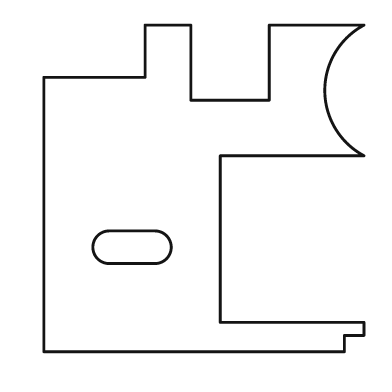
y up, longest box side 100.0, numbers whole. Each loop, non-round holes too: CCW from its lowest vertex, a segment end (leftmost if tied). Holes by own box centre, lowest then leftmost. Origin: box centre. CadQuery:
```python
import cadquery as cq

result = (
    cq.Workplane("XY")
    .moveTo(-49.0, -50.0)
    .lineTo(43.0, -50.0)
    .lineTo(43.0, -45.0)
    .lineTo(49.0, -45.0)
    .lineTo(49.0, -41.0)
    .lineTo(5.0, -41.0)
    .lineTo(5.0, 10.0)
    .lineTo(49.0, 10.0)
    .threePointArc((37.0, 30.0), (49.0, 50.0))
    .lineTo(20.0, 50.0)
    .lineTo(20.0, 27.0)
    .lineTo(-4.0, 27.0)
    .lineTo(-4.0, 50.0)
    .lineTo(-18.0, 50.0)
    .lineTo(-18.0, 34.0)
    .lineTo(-49.0, 34.0)
    .close()
    .moveTo(-29.0, -23.0)
    .lineTo(-15.0, -23.0)
    .threePointArc((-10.0, -18.0), (-15.0, -13.0))
    .lineTo(-29.0, -13.0)
    .threePointArc((-34.0, -18.0), (-29.0, -23.0))
    .close()
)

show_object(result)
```